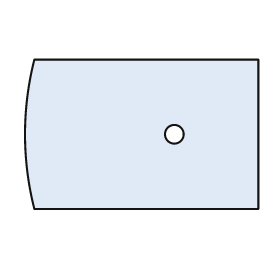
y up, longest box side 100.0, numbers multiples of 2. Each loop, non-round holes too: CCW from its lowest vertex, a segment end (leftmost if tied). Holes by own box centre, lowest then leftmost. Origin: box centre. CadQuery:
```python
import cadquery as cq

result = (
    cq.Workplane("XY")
    .moveTo(-46.0, -32.0)
    .lineTo(50.0, -32.0)
    .lineTo(50.0, 32.0)
    .lineTo(-46.0, 32.0)
    .threePointArc((-50.0, 0.0), (-46.0, -32.0))
    .close()
    .moveTo(14.0, 0.0)
    .circle(4.0)
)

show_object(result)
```